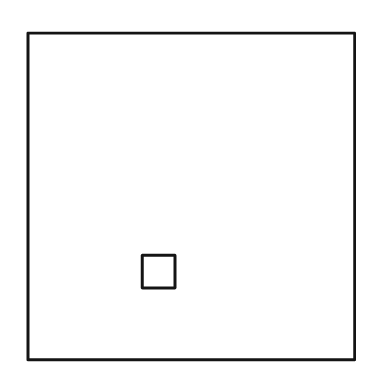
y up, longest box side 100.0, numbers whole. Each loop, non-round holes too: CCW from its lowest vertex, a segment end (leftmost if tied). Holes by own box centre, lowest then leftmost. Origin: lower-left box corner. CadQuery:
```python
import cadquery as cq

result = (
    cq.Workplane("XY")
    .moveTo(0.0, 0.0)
    .lineTo(100.0, 0.0)
    .lineTo(100.0, 100.0)
    .lineTo(0.0, 100.0)
    .close()
    .moveTo(35.0, 22.0)
    .lineTo(45.0, 22.0)
    .lineTo(45.0, 32.0)
    .lineTo(35.0, 32.0)
    .close()
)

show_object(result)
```